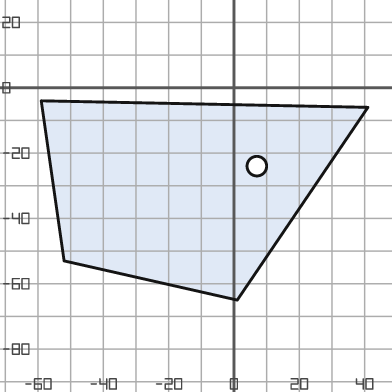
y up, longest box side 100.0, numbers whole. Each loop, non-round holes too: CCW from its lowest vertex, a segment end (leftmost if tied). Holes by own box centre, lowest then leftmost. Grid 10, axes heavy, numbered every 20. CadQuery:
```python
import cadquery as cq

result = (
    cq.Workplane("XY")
    .moveTo(1.0, -65.0)
    .lineTo(41.0, -6.0)
    .lineTo(-59.0, -4.0)
    .lineTo(-52.0, -53.0)
    .close()
    .moveTo(7.0, -24.0)
    .circle(3.0)
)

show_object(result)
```